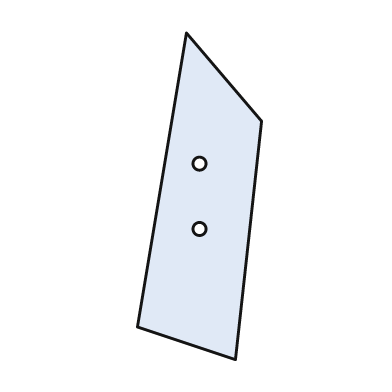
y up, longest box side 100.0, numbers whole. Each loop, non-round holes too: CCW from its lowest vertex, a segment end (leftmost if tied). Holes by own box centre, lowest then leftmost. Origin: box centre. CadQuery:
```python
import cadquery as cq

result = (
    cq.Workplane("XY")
    .moveTo(11.0, -50.0)
    .lineTo(19.0, 23.0)
    .lineTo(-4.0, 50.0)
    .lineTo(-19.0, -40.0)
    .close()
    .moveTo(0.0, -10.0)
    .circle(2.0)
    .moveTo(0.0, 10.0)
    .circle(2.0)
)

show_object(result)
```